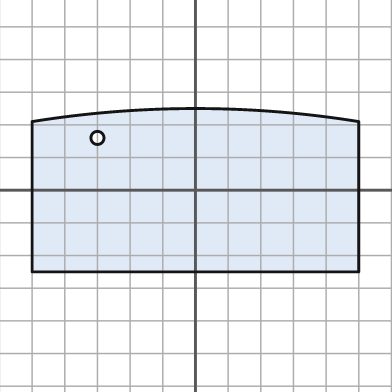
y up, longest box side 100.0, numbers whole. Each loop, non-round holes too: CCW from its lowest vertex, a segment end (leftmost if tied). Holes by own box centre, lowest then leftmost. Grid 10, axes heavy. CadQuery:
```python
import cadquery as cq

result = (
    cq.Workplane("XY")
    .moveTo(-50.0, -25.0)
    .lineTo(50.0, -25.0)
    .lineTo(50.0, 21.0)
    .threePointArc((0.0, 25.0), (-50.0, 21.0))
    .close()
    .moveTo(-30.0, 16.0)
    .circle(2.0)
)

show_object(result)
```